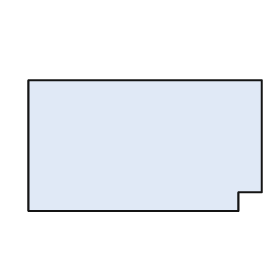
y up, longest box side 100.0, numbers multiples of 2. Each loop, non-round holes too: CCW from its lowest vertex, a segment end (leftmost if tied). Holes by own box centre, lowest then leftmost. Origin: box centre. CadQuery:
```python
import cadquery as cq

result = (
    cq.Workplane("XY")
    .moveTo(-50.0, -28.0)
    .lineTo(40.0, -28.0)
    .lineTo(40.0, -20.0)
    .lineTo(50.0, -20.0)
    .lineTo(50.0, 28.0)
    .lineTo(-50.0, 28.0)
    .close()
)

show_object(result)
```